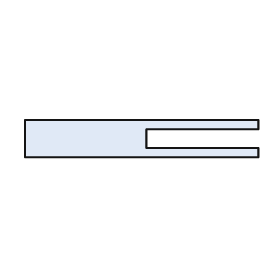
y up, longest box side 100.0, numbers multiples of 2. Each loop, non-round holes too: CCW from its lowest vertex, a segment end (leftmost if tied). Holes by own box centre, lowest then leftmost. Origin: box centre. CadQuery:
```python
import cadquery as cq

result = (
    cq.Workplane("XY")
    .moveTo(-50.0, -8.0)
    .lineTo(50.0, -8.0)
    .lineTo(50.0, -4.0)
    .lineTo(2.0, -4.0)
    .lineTo(2.0, 4.0)
    .lineTo(50.0, 4.0)
    .lineTo(50.0, 8.0)
    .lineTo(-50.0, 8.0)
    .close()
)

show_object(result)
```